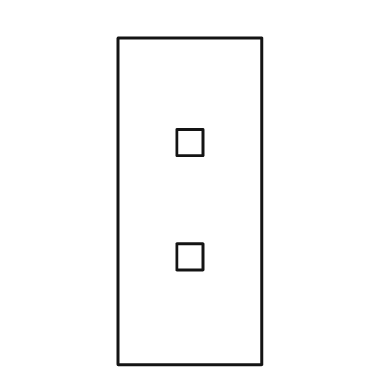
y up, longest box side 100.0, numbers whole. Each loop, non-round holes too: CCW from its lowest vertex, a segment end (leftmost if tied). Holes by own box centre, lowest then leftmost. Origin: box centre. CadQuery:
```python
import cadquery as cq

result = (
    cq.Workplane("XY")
    .moveTo(-22.0, -50.0)
    .lineTo(22.0, -50.0)
    .lineTo(22.0, 50.0)
    .lineTo(-22.0, 50.0)
    .close()
    .moveTo(-4.0, -21.0)
    .lineTo(4.0, -21.0)
    .lineTo(4.0, -13.0)
    .lineTo(-4.0, -13.0)
    .close()
    .moveTo(-4.0, 14.0)
    .lineTo(4.0, 14.0)
    .lineTo(4.0, 22.0)
    .lineTo(-4.0, 22.0)
    .close()
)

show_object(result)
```